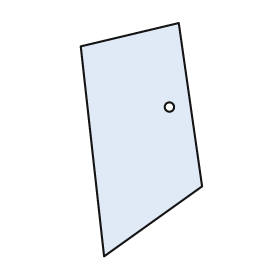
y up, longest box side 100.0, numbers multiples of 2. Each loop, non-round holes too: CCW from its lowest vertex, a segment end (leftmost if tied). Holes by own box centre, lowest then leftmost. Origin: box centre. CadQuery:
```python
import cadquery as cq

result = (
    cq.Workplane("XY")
    .moveTo(-16.0, -50.0)
    .lineTo(26.0, -20.0)
    .lineTo(16.0, 50.0)
    .lineTo(-26.0, 40.0)
    .close()
    .moveTo(12.0, 14.0)
    .circle(2.0)
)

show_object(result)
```